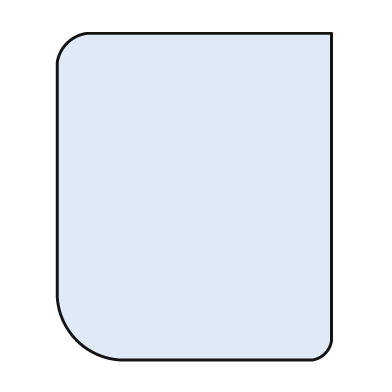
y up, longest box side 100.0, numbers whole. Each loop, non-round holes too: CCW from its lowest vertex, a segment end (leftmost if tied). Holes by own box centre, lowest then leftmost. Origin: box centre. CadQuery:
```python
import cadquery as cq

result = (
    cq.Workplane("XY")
    .moveTo(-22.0, -50.0)
    .lineTo(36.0, -50.0)
    .threePointArc((40.0, -48.0), (42.0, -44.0))
    .lineTo(42.0, 50.0)
    .lineTo(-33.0, 50.0)
    .threePointArc((-39.0, 47.0), (-42.0, 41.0))
    .lineTo(-42.0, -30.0)
    .threePointArc((-36.0, -44.0), (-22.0, -50.0))
    .close()
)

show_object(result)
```